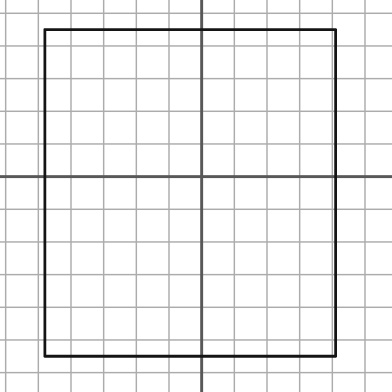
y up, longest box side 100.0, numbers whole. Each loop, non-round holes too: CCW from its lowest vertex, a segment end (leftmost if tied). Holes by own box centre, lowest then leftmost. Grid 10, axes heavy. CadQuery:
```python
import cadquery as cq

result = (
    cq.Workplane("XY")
    .moveTo(-48.0, -55.0)
    .lineTo(41.0, -55.0)
    .lineTo(41.0, 45.0)
    .lineTo(-48.0, 45.0)
    .close()
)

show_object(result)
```